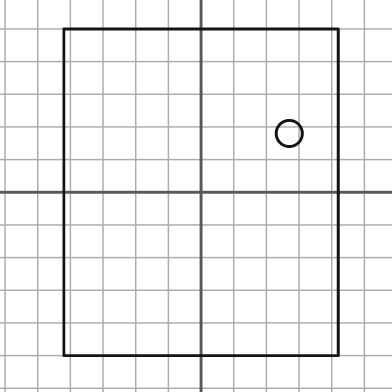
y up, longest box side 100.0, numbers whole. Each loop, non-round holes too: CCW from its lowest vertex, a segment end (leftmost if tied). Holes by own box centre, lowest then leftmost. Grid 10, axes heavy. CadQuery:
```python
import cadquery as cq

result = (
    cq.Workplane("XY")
    .moveTo(-42.0, -50.0)
    .lineTo(42.0, -50.0)
    .lineTo(42.0, 50.0)
    .lineTo(-42.0, 50.0)
    .close()
    .moveTo(27.0, 18.0)
    .circle(4.0)
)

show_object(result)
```